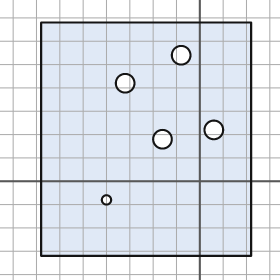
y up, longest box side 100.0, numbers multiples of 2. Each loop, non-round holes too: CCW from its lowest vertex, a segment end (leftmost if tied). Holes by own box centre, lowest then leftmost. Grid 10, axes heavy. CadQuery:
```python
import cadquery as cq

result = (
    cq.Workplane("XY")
    .moveTo(-68.0, -32.0)
    .lineTo(22.0, -32.0)
    .lineTo(22.0, 68.0)
    .lineTo(-68.0, 68.0)
    .close()
    .moveTo(-40.0, -8.0)
    .circle(2.0)
    .moveTo(-16.0, 18.0)
    .circle(4.0)
    .moveTo(6.0, 22.0)
    .circle(4.0)
    .moveTo(-32.0, 42.0)
    .circle(4.0)
    .moveTo(-8.0, 54.0)
    .circle(4.0)
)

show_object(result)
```